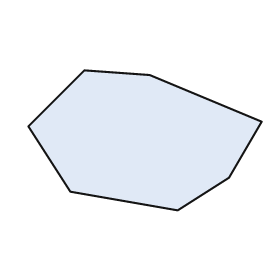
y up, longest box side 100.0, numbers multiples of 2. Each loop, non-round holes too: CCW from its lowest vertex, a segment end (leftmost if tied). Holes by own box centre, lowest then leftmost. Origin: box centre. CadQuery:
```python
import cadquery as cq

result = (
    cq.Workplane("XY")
    .moveTo(14.0, -30.0)
    .lineTo(36.0, -16.0)
    .lineTo(50.0, 8.0)
    .lineTo(2.0, 28.0)
    .lineTo(-26.0, 30.0)
    .lineTo(-50.0, 6.0)
    .lineTo(-32.0, -22.0)
    .close()
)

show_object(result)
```